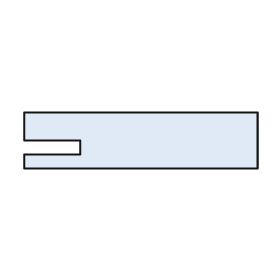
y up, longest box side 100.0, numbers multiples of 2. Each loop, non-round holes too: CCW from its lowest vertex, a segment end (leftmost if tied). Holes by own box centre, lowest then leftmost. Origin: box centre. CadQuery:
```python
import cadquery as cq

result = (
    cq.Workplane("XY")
    .moveTo(-50.0, -12.0)
    .lineTo(50.0, -12.0)
    .lineTo(50.0, 12.0)
    .lineTo(-50.0, 12.0)
    .lineTo(-50.0, 0.0)
    .lineTo(-26.0, 0.0)
    .lineTo(-26.0, -6.0)
    .lineTo(-50.0, -6.0)
    .close()
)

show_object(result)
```